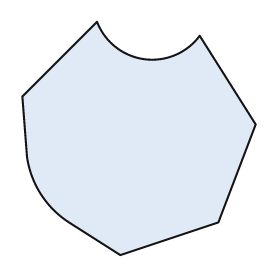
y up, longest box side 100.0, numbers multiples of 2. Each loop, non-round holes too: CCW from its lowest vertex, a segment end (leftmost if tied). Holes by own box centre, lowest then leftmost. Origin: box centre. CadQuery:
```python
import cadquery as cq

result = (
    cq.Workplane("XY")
    .moveTo(-8.0, -50.0)
    .lineTo(34.0, -36.0)
    .lineTo(50.0, 6.0)
    .lineTo(26.0, 44.0)
    .threePointArc((2.0, 34.0), (-18.0, 50.0))
    .lineTo(-50.0, 18.0)
    .lineTo(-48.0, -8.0)
    .threePointArc((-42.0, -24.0), (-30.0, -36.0))
    .close()
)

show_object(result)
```